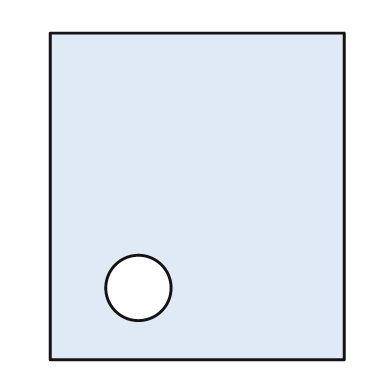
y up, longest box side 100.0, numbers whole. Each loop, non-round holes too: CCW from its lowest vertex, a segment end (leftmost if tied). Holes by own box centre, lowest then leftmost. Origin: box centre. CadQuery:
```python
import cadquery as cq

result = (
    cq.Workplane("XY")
    .moveTo(-45.0, -50.0)
    .lineTo(45.0, -50.0)
    .lineTo(45.0, 50.0)
    .lineTo(-45.0, 50.0)
    .close()
    .moveTo(-18.0, -28.0)
    .circle(10.0)
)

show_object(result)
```